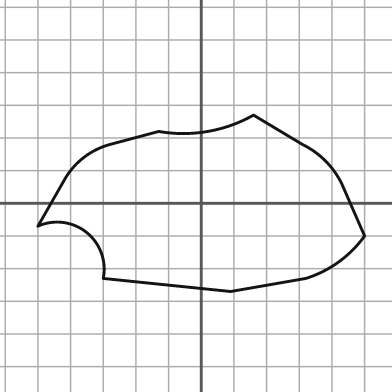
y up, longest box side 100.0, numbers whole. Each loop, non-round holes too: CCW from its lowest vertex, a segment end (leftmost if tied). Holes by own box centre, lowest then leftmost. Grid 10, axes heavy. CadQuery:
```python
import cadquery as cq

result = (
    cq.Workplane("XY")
    .moveTo(9.0, -27.0)
    .lineTo(32.0, -23.0)
    .threePointArc((42.0, -18.0), (50.0, -10.0))
    .lineTo(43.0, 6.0)
    .threePointArc((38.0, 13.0), (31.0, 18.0))
    .lineTo(16.0, 27.0)
    .threePointArc((2.0, 22.0), (-13.0, 22.0))
    .lineTo(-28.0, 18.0)
    .threePointArc((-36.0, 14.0), (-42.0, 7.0))
    .lineTo(-50.0, -7.0)
    .threePointArc((-35.0, -9.0), (-30.0, -23.0))
    .close()
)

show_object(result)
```